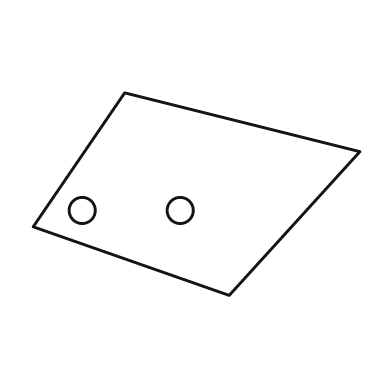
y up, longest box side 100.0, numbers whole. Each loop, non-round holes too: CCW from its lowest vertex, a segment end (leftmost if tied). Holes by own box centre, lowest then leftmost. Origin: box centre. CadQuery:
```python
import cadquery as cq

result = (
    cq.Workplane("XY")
    .moveTo(10.0, -31.0)
    .lineTo(50.0, 13.0)
    .lineTo(-22.0, 31.0)
    .lineTo(-50.0, -10.0)
    .close()
    .moveTo(-35.0, -5.0)
    .circle(4.0)
    .moveTo(-5.0, -5.0)
    .circle(4.0)
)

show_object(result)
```